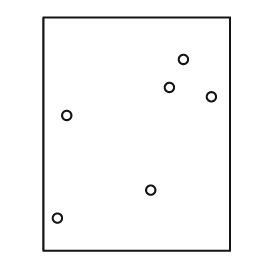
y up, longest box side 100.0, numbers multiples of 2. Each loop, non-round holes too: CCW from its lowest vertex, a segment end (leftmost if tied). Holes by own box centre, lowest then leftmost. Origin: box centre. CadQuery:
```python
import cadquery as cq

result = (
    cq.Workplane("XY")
    .moveTo(-40.0, -50.0)
    .lineTo(40.0, -50.0)
    .lineTo(40.0, 50.0)
    .lineTo(-40.0, 50.0)
    .close()
    .moveTo(-34.0, -36.0)
    .circle(2.0)
    .moveTo(6.0, -24.0)
    .circle(2.0)
    .moveTo(-30.0, 8.0)
    .circle(2.0)
    .moveTo(32.0, 16.0)
    .circle(2.0)
    .moveTo(14.0, 20.0)
    .circle(2.0)
    .moveTo(20.0, 32.0)
    .circle(2.0)
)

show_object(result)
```